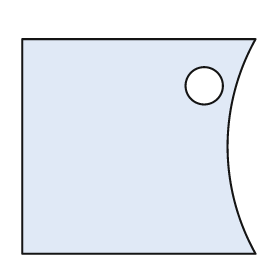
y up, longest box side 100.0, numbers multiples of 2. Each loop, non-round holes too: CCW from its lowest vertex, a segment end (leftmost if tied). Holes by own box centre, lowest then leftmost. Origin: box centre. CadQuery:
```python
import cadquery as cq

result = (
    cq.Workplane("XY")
    .moveTo(-50.0, -46.0)
    .lineTo(50.0, -46.0)
    .threePointArc((38.0, 0.0), (50.0, 46.0))
    .lineTo(-50.0, 46.0)
    .close()
    .moveTo(28.0, 26.0)
    .circle(8.0)
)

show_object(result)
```